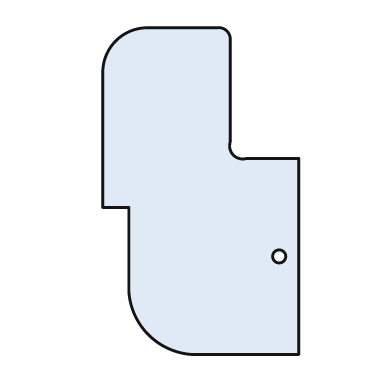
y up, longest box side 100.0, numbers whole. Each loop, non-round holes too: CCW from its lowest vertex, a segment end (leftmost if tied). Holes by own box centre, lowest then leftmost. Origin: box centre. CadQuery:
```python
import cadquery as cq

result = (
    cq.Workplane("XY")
    .moveTo(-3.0, -50.0)
    .lineTo(30.0, -50.0)
    .lineTo(30.0, 10.0)
    .lineTo(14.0, 10.0)
    .threePointArc((10.0, 11.0), (9.0, 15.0))
    .lineTo(9.0, 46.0)
    .threePointArc((8.0, 49.0), (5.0, 50.0))
    .lineTo(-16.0, 50.0)
    .threePointArc((-26.0, 46.0), (-30.0, 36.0))
    .lineTo(-30.0, -5.0)
    .lineTo(-22.0, -5.0)
    .lineTo(-22.0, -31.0)
    .threePointArc((-16.0, -44.0), (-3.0, -50.0))
    .close()
    .moveTo(24.0, -20.0)
    .circle(2.0)
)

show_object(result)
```